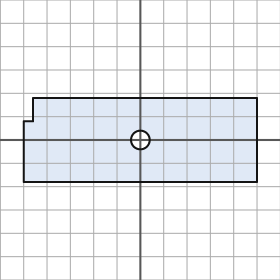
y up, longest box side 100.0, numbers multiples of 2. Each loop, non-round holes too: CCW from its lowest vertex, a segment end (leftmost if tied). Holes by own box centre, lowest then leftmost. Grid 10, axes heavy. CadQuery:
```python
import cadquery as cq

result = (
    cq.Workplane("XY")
    .moveTo(-50.0, -18.0)
    .lineTo(50.0, -18.0)
    .lineTo(50.0, 18.0)
    .lineTo(-46.0, 18.0)
    .lineTo(-46.0, 8.0)
    .lineTo(-50.0, 8.0)
    .close()
    .moveTo(0.0, 0.0)
    .circle(4.0)
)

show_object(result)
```